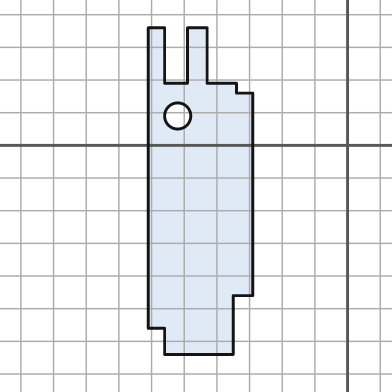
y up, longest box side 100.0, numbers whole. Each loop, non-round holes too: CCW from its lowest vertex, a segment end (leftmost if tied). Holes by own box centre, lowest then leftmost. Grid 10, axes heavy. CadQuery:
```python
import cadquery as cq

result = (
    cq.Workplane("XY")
    .moveTo(-56.0, -64.0)
    .lineTo(-35.0, -64.0)
    .lineTo(-35.0, -46.0)
    .lineTo(-29.0, -46.0)
    .lineTo(-29.0, 16.0)
    .lineTo(-34.0, 16.0)
    .lineTo(-34.0, 19.0)
    .lineTo(-43.0, 19.0)
    .lineTo(-43.0, 36.0)
    .lineTo(-49.0, 36.0)
    .lineTo(-49.0, 19.0)
    .lineTo(-56.0, 19.0)
    .lineTo(-56.0, 36.0)
    .lineTo(-61.0, 36.0)
    .lineTo(-61.0, -56.0)
    .lineTo(-56.0, -56.0)
    .close()
    .moveTo(-52.0, 9.0)
    .circle(4.0)
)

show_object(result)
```